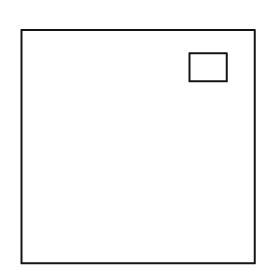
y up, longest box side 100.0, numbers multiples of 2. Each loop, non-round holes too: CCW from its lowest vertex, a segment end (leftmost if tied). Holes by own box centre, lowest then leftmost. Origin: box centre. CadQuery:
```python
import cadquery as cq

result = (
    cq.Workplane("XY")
    .moveTo(-50.0, -50.0)
    .lineTo(50.0, -50.0)
    .lineTo(50.0, 50.0)
    .lineTo(-50.0, 50.0)
    .close()
    .moveTo(22.0, 28.0)
    .lineTo(38.0, 28.0)
    .lineTo(38.0, 40.0)
    .lineTo(22.0, 40.0)
    .close()
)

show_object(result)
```